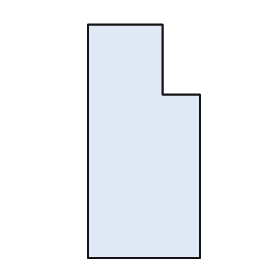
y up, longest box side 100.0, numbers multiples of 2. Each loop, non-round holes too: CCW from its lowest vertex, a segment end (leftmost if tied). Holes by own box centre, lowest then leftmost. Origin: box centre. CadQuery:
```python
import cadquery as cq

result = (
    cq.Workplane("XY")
    .moveTo(-24.0, -50.0)
    .lineTo(24.0, -50.0)
    .lineTo(24.0, 20.0)
    .lineTo(8.0, 20.0)
    .lineTo(8.0, 50.0)
    .lineTo(-24.0, 50.0)
    .close()
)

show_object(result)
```